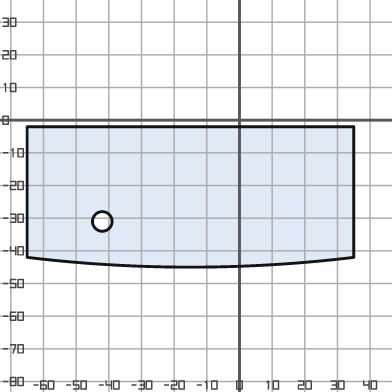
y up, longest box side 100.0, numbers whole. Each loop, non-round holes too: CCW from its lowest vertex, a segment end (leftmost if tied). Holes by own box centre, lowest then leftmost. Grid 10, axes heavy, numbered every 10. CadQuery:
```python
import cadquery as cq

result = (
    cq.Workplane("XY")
    .moveTo(-65.0, -42.0)
    .threePointArc((-15.0, -45.0), (35.0, -42.0))
    .lineTo(35.0, -2.0)
    .lineTo(-65.0, -2.0)
    .close()
    .moveTo(-42.0, -31.0)
    .circle(3.0)
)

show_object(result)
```